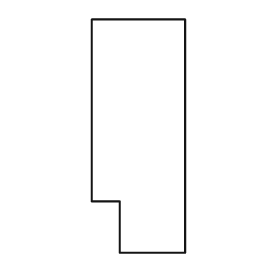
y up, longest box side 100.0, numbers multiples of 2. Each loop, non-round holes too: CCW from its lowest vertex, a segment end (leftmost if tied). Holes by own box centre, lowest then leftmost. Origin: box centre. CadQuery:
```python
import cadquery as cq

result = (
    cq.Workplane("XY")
    .moveTo(-8.0, -50.0)
    .lineTo(20.0, -50.0)
    .lineTo(20.0, 50.0)
    .lineTo(-20.0, 50.0)
    .lineTo(-20.0, -28.0)
    .lineTo(-8.0, -28.0)
    .close()
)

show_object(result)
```